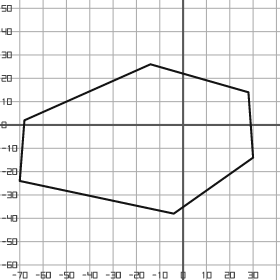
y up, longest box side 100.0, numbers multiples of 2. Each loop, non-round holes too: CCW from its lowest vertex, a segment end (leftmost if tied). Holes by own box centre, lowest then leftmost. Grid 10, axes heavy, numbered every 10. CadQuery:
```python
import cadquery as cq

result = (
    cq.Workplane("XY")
    .moveTo(-4.0, -38.0)
    .lineTo(30.0, -14.0)
    .lineTo(28.0, 14.0)
    .lineTo(-14.0, 26.0)
    .lineTo(-68.0, 2.0)
    .lineTo(-70.0, -24.0)
    .close()
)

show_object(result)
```